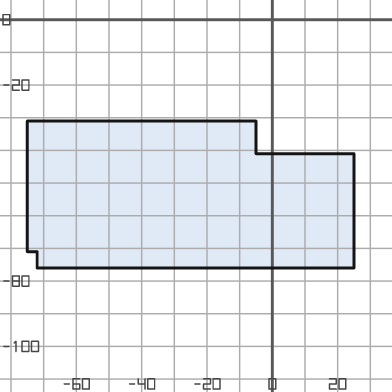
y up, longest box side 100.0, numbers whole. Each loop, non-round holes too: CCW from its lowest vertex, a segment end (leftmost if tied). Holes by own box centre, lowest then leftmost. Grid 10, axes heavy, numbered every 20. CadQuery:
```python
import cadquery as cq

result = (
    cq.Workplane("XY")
    .moveTo(-72.0, -76.0)
    .lineTo(25.0, -76.0)
    .lineTo(25.0, -41.0)
    .lineTo(-5.0, -41.0)
    .lineTo(-5.0, -31.0)
    .lineTo(-75.0, -31.0)
    .lineTo(-75.0, -71.0)
    .lineTo(-72.0, -71.0)
    .close()
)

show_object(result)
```